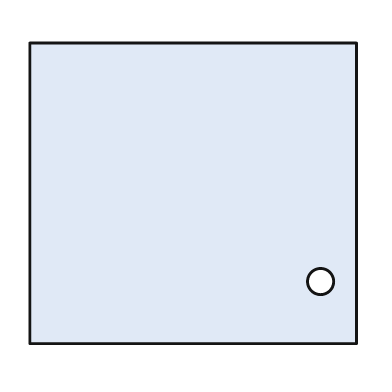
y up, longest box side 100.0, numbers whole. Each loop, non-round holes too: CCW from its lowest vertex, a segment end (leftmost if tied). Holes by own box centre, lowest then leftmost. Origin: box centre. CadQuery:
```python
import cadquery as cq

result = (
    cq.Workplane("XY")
    .moveTo(-50.0, -46.0)
    .lineTo(50.0, -46.0)
    .lineTo(50.0, 46.0)
    .lineTo(-50.0, 46.0)
    .close()
    .moveTo(39.0, -27.0)
    .circle(4.0)
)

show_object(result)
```